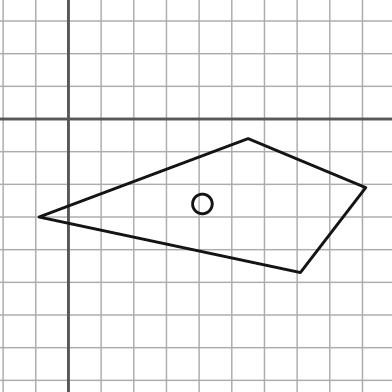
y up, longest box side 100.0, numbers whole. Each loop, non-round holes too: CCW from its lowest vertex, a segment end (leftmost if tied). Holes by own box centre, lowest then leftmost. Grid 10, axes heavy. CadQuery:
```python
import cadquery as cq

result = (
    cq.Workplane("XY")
    .moveTo(71.0, -47.0)
    .lineTo(91.0, -21.0)
    .lineTo(55.0, -6.0)
    .lineTo(-9.0, -30.0)
    .close()
    .moveTo(41.0, -26.0)
    .circle(3.0)
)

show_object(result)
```